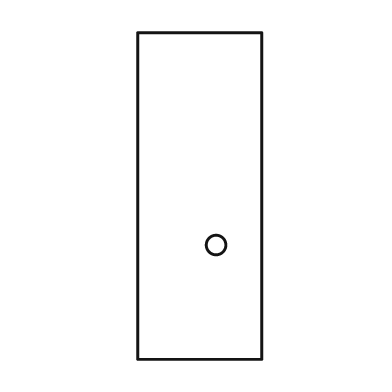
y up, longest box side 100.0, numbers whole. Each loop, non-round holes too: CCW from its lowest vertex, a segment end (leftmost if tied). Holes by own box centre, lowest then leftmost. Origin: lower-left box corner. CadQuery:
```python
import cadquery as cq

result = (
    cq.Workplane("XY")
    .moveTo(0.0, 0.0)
    .lineTo(38.0, 0.0)
    .lineTo(38.0, 100.0)
    .lineTo(0.0, 100.0)
    .close()
    .moveTo(24.0, 35.0)
    .circle(3.0)
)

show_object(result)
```